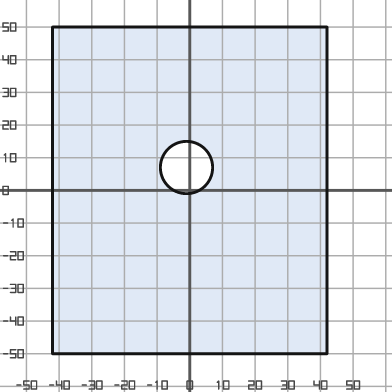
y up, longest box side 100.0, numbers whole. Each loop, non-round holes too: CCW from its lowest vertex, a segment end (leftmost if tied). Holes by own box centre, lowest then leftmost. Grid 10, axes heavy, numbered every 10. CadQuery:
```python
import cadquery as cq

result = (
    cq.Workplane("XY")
    .moveTo(-42.0, -50.0)
    .lineTo(42.0, -50.0)
    .lineTo(42.0, 50.0)
    .lineTo(-42.0, 50.0)
    .close()
    .moveTo(-1.0, 7.0)
    .circle(8.0)
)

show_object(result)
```